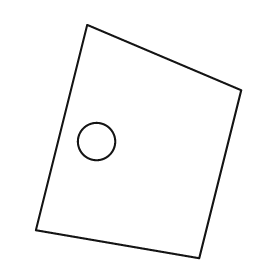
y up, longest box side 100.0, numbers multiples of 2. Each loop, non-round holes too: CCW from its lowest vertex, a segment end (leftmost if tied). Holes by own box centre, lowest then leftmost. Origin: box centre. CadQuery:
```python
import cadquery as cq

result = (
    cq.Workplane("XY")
    .moveTo(26.0, -50.0)
    .lineTo(44.0, 22.0)
    .lineTo(-22.0, 50.0)
    .lineTo(-44.0, -38.0)
    .close()
    .moveTo(-18.0, 0.0)
    .circle(8.0)
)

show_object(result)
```